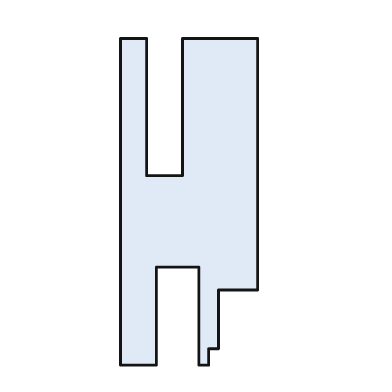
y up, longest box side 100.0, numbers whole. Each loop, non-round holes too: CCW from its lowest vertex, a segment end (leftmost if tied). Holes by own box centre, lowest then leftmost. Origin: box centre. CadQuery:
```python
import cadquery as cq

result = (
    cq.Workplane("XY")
    .moveTo(-21.0, -50.0)
    .lineTo(-10.0, -50.0)
    .lineTo(-10.0, -20.0)
    .lineTo(3.0, -20.0)
    .lineTo(3.0, -50.0)
    .lineTo(6.0, -50.0)
    .lineTo(6.0, -45.0)
    .lineTo(9.0, -45.0)
    .lineTo(9.0, -27.0)
    .lineTo(21.0, -27.0)
    .lineTo(21.0, 50.0)
    .lineTo(-2.0, 50.0)
    .lineTo(-2.0, 8.0)
    .lineTo(-13.0, 8.0)
    .lineTo(-13.0, 50.0)
    .lineTo(-21.0, 50.0)
    .close()
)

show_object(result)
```